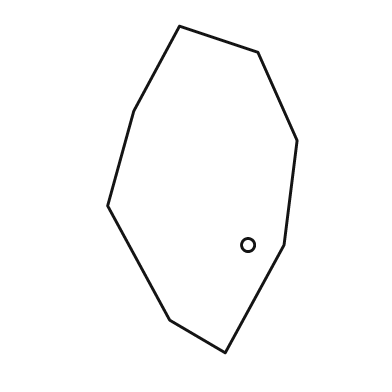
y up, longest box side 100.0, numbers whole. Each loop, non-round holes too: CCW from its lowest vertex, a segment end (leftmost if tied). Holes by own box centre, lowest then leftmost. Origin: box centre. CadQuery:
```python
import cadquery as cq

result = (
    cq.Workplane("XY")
    .moveTo(7.0, -50.0)
    .lineTo(25.0, -17.0)
    .lineTo(29.0, 15.0)
    .lineTo(17.0, 42.0)
    .lineTo(-7.0, 50.0)
    .lineTo(-21.0, 24.0)
    .lineTo(-29.0, -5.0)
    .lineTo(-10.0, -40.0)
    .close()
    .moveTo(14.0, -17.0)
    .circle(2.0)
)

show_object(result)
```